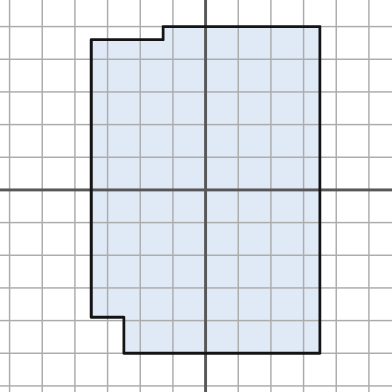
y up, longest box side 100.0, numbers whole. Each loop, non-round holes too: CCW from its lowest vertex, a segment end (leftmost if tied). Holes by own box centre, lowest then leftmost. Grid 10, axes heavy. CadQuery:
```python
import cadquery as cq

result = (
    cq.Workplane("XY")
    .moveTo(-25.0, -50.0)
    .lineTo(35.0, -50.0)
    .lineTo(35.0, 50.0)
    .lineTo(-13.0, 50.0)
    .lineTo(-13.0, 46.0)
    .lineTo(-35.0, 46.0)
    .lineTo(-35.0, -39.0)
    .lineTo(-25.0, -39.0)
    .close()
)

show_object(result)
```